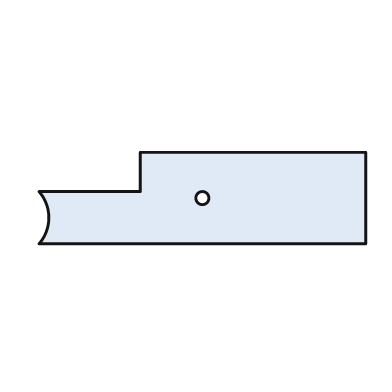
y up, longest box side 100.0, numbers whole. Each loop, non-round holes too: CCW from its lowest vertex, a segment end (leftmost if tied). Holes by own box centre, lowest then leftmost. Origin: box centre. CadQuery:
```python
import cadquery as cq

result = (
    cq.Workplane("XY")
    .moveTo(-50.0, -14.0)
    .lineTo(50.0, -14.0)
    .lineTo(50.0, 14.0)
    .lineTo(-19.0, 14.0)
    .lineTo(-19.0, 2.0)
    .lineTo(-50.0, 2.0)
    .threePointArc((-47.0, -6.0), (-50.0, -14.0))
    .close()
    .moveTo(0.0, 0.0)
    .circle(2.0)
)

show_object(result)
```